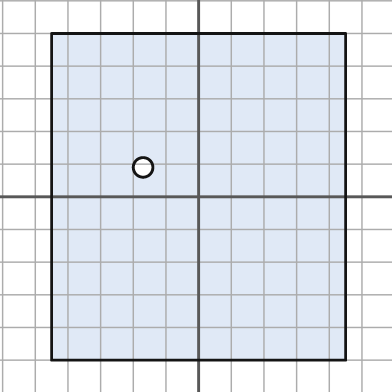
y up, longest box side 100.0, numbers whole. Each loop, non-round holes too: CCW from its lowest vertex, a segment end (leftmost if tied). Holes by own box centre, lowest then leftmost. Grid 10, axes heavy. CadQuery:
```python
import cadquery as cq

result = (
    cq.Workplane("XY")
    .moveTo(-45.0, -50.0)
    .lineTo(45.0, -50.0)
    .lineTo(45.0, 50.0)
    .lineTo(-45.0, 50.0)
    .close()
    .moveTo(-17.0, 9.0)
    .circle(3.0)
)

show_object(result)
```